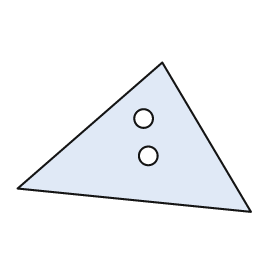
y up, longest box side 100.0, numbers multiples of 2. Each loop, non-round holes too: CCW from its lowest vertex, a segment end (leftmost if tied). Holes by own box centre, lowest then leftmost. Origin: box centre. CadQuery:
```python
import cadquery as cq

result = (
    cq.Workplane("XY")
    .moveTo(50.0, -32.0)
    .lineTo(12.0, 32.0)
    .lineTo(-50.0, -22.0)
    .close()
    .moveTo(6.0, -8.0)
    .circle(4.0)
    .moveTo(4.0, 8.0)
    .circle(4.0)
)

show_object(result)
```